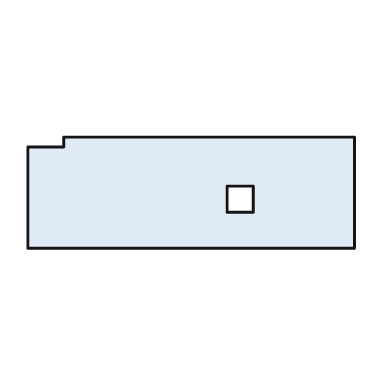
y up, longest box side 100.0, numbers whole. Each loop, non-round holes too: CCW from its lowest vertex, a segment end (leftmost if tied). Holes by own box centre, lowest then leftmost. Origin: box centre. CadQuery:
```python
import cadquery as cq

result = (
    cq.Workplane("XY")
    .moveTo(-50.0, -17.0)
    .lineTo(50.0, -17.0)
    .lineTo(50.0, 17.0)
    .lineTo(-39.0, 17.0)
    .lineTo(-39.0, 14.0)
    .lineTo(-50.0, 14.0)
    .close()
    .moveTo(11.0, -6.0)
    .lineTo(19.0, -6.0)
    .lineTo(19.0, 2.0)
    .lineTo(11.0, 2.0)
    .close()
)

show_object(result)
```